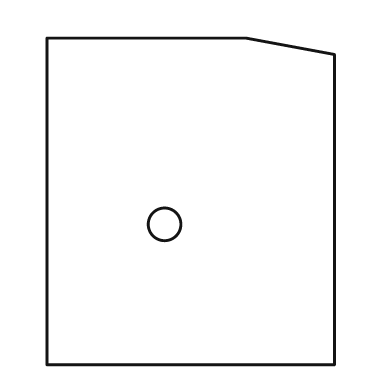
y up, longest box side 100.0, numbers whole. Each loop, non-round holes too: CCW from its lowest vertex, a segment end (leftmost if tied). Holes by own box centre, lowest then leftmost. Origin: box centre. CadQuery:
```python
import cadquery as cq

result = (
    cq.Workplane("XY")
    .moveTo(-44.0, -50.0)
    .lineTo(44.0, -50.0)
    .lineTo(44.0, 45.0)
    .lineTo(17.0, 50.0)
    .lineTo(-44.0, 50.0)
    .close()
    .moveTo(-8.0, -7.0)
    .circle(5.0)
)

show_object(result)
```